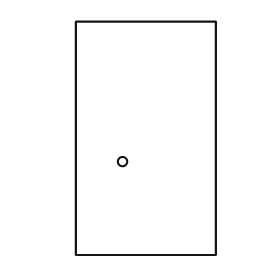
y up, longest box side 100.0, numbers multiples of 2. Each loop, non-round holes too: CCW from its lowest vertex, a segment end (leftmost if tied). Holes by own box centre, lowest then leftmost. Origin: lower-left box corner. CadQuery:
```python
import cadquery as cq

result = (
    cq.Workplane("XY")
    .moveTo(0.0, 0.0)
    .lineTo(60.0, 0.0)
    .lineTo(60.0, 100.0)
    .lineTo(0.0, 100.0)
    .close()
    .moveTo(20.0, 40.0)
    .circle(2.0)
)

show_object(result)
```